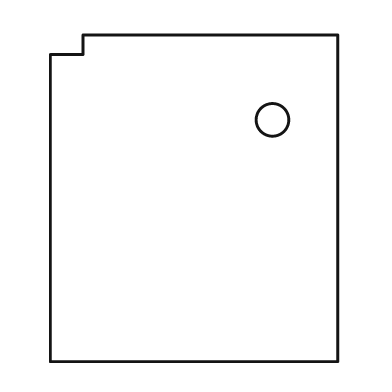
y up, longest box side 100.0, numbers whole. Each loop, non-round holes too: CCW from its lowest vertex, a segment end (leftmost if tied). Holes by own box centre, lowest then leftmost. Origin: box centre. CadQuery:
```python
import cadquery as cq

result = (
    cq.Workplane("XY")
    .moveTo(-44.0, -50.0)
    .lineTo(44.0, -50.0)
    .lineTo(44.0, 50.0)
    .lineTo(-34.0, 50.0)
    .lineTo(-34.0, 44.0)
    .lineTo(-44.0, 44.0)
    .close()
    .moveTo(24.0, 24.0)
    .circle(5.0)
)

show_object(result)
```